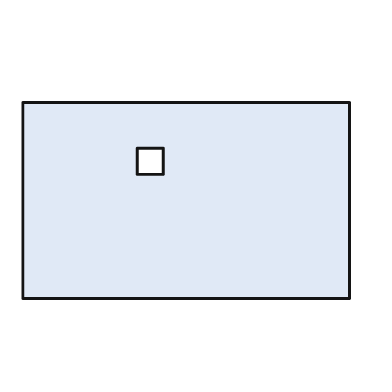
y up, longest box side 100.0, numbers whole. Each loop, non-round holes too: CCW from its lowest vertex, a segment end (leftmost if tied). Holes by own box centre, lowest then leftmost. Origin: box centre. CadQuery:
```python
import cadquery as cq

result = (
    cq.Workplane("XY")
    .moveTo(-50.0, -30.0)
    .lineTo(50.0, -30.0)
    .lineTo(50.0, 30.0)
    .lineTo(-50.0, 30.0)
    .close()
    .moveTo(-15.0, 8.0)
    .lineTo(-7.0, 8.0)
    .lineTo(-7.0, 16.0)
    .lineTo(-15.0, 16.0)
    .close()
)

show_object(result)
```